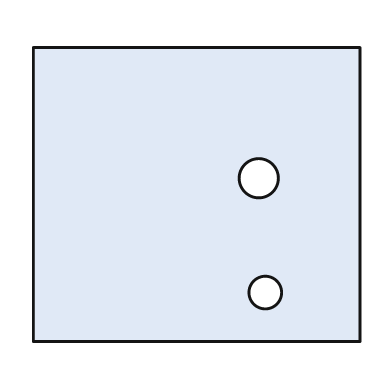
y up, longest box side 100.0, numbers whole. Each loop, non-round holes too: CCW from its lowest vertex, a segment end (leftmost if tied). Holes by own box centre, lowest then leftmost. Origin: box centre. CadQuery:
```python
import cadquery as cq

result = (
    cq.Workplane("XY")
    .moveTo(-50.0, -45.0)
    .lineTo(50.0, -45.0)
    .lineTo(50.0, 45.0)
    .lineTo(-50.0, 45.0)
    .close()
    .moveTo(21.0, -30.0)
    .circle(5.0)
    .moveTo(19.0, 5.0)
    .circle(6.0)
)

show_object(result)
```